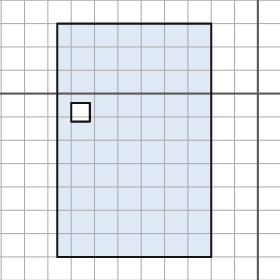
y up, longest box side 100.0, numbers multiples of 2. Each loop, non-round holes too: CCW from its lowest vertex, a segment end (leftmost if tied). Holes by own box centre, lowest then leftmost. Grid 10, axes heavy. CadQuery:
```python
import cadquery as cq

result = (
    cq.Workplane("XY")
    .moveTo(-86.0, -70.0)
    .lineTo(-20.0, -70.0)
    .lineTo(-20.0, 30.0)
    .lineTo(-86.0, 30.0)
    .close()
    .moveTo(-80.0, -12.0)
    .lineTo(-72.0, -12.0)
    .lineTo(-72.0, -4.0)
    .lineTo(-80.0, -4.0)
    .close()
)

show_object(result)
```